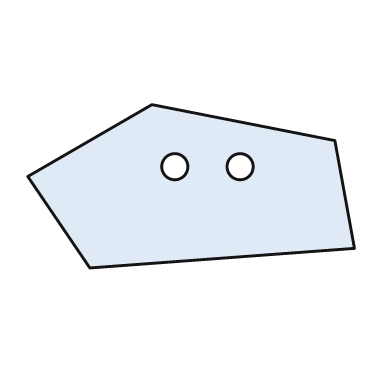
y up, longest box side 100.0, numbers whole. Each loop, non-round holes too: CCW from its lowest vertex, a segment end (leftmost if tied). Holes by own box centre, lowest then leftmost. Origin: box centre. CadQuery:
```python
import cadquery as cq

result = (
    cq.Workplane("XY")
    .moveTo(-31.0, -25.0)
    .lineTo(50.0, -19.0)
    .lineTo(44.0, 14.0)
    .lineTo(-12.0, 25.0)
    .lineTo(-50.0, 3.0)
    .close()
    .moveTo(-5.0, 6.0)
    .circle(4.0)
    .moveTo(15.0, 6.0)
    .circle(4.0)
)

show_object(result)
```